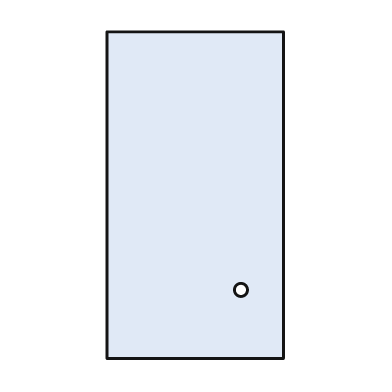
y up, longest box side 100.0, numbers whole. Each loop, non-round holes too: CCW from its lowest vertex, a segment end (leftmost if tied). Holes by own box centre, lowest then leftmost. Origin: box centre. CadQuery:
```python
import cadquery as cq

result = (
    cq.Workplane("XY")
    .moveTo(-27.0, -50.0)
    .lineTo(27.0, -50.0)
    .lineTo(27.0, 50.0)
    .lineTo(-27.0, 50.0)
    .close()
    .moveTo(14.0, -29.0)
    .circle(2.0)
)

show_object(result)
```